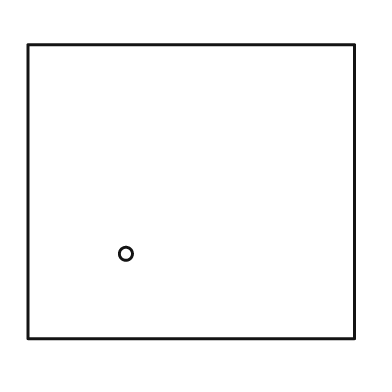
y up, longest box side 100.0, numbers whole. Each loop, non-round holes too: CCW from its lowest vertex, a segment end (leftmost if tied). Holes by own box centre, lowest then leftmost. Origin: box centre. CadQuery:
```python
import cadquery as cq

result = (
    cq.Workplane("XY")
    .moveTo(-50.0, -45.0)
    .lineTo(50.0, -45.0)
    .lineTo(50.0, 45.0)
    .lineTo(-50.0, 45.0)
    .close()
    .moveTo(-20.0, -19.0)
    .circle(2.0)
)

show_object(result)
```